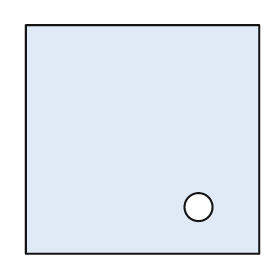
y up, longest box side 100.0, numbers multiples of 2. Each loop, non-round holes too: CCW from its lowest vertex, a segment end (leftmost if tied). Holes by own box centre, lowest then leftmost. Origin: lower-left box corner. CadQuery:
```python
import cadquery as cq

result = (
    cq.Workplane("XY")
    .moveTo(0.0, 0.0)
    .lineTo(100.0, 0.0)
    .lineTo(100.0, 98.0)
    .lineTo(0.0, 98.0)
    .close()
    .moveTo(74.0, 20.0)
    .circle(6.0)
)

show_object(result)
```